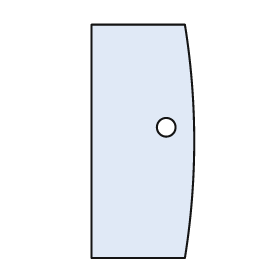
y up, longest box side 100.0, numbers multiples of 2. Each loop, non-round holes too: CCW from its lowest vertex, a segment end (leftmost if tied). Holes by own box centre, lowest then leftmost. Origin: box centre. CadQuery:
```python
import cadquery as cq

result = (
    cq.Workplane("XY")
    .moveTo(-22.0, -50.0)
    .lineTo(18.0, -50.0)
    .threePointArc((22.0, 0.0), (18.0, 50.0))
    .lineTo(-22.0, 50.0)
    .close()
    .moveTo(10.0, 6.0)
    .circle(4.0)
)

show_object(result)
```